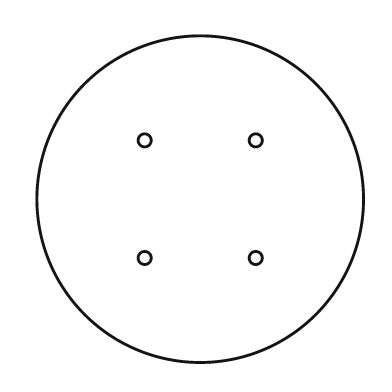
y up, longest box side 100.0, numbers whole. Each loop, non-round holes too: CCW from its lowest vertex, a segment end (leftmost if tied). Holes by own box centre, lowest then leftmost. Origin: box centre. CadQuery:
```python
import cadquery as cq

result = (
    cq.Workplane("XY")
    .moveTo(0.0, 0.0)
    .circle(50.0)
    .moveTo(-17.0, -18.0)
    .circle(2.0)
    .moveTo(17.0, -18.0)
    .circle(2.0)
    .moveTo(-17.0, 18.0)
    .circle(2.0)
    .moveTo(17.0, 18.0)
    .circle(2.0)
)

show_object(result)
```